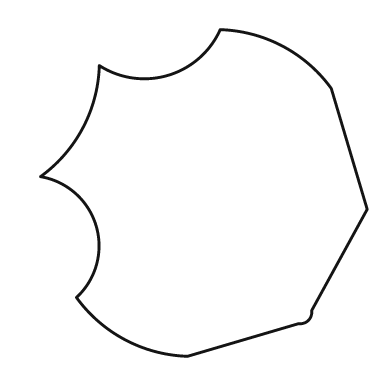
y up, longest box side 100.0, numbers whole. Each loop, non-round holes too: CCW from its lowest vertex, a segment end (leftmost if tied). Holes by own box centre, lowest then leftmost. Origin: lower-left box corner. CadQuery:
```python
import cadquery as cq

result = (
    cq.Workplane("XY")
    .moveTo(45.0, 0.0)
    .lineTo(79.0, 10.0)
    .threePointArc((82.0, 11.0), (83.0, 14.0))
    .lineTo(100.0, 45.0)
    .lineTo(89.0, 82.0)
    .threePointArc((74.0, 95.0), (55.0, 100.0))
    .threePointArc((39.0, 86.0), (18.0, 89.0))
    .threePointArc((13.0, 70.0), (0.0, 55.0))
    .threePointArc((17.0, 40.0), (11.0, 18.0))
    .threePointArc((26.0, 5.0), (45.0, 0.0))
    .close()
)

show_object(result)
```